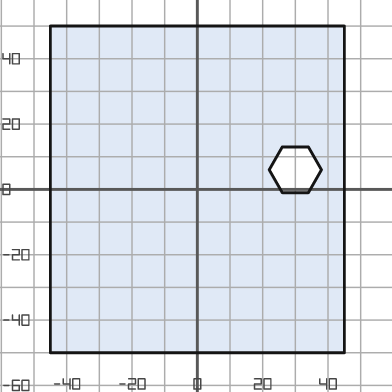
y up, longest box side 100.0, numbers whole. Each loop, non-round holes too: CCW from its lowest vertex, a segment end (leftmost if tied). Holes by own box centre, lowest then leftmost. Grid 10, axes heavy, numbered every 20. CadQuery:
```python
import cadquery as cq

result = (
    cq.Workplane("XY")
    .moveTo(-45.0, -50.0)
    .lineTo(45.0, -50.0)
    .lineTo(45.0, 50.0)
    .lineTo(-45.0, 50.0)
    .close()
    .moveTo(26.0, -1.0)
    .lineTo(34.0, -1.0)
    .lineTo(38.0, 6.0)
    .lineTo(34.0, 13.0)
    .lineTo(26.0, 13.0)
    .lineTo(22.0, 6.0)
    .close()
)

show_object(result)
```